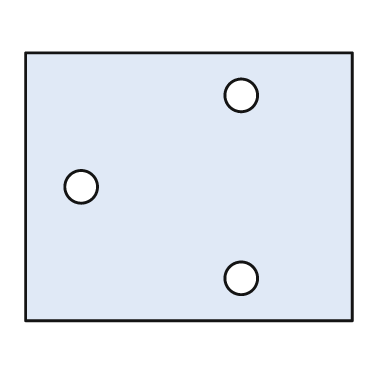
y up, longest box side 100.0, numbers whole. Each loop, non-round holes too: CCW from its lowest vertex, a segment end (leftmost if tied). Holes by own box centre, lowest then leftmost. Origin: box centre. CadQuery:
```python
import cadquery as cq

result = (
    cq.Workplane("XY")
    .moveTo(-50.0, -41.0)
    .lineTo(50.0, -41.0)
    .lineTo(50.0, 41.0)
    .lineTo(-50.0, 41.0)
    .close()
    .moveTo(16.0, -28.0)
    .circle(5.0)
    .moveTo(-33.0, 0.0)
    .circle(5.0)
    .moveTo(16.0, 28.0)
    .circle(5.0)
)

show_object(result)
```